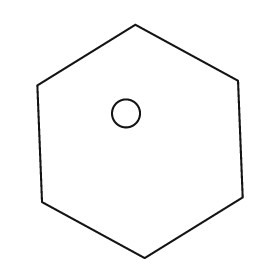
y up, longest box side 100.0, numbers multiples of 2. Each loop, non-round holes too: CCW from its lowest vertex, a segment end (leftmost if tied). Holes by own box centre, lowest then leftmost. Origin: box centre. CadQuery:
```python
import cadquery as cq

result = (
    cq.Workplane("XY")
    .moveTo(2.0, -50.0)
    .lineTo(44.0, -24.0)
    .lineTo(42.0, 26.0)
    .lineTo(-2.0, 50.0)
    .lineTo(-44.0, 24.0)
    .lineTo(-42.0, -26.0)
    .close()
    .moveTo(-6.0, 12.0)
    .circle(6.0)
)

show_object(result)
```